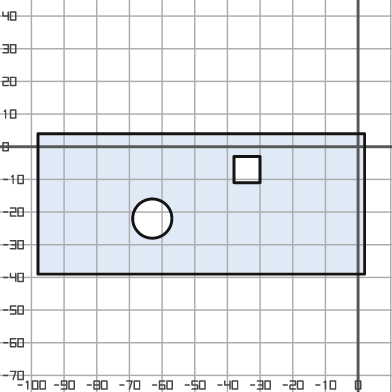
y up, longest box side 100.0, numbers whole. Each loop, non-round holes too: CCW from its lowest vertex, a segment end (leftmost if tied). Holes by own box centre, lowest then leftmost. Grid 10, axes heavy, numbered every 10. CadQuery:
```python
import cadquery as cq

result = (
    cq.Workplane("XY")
    .moveTo(-98.0, -39.0)
    .lineTo(2.0, -39.0)
    .lineTo(2.0, 4.0)
    .lineTo(-98.0, 4.0)
    .close()
    .moveTo(-63.0, -22.0)
    .circle(6.0)
    .moveTo(-38.0, -11.0)
    .lineTo(-30.0, -11.0)
    .lineTo(-30.0, -3.0)
    .lineTo(-38.0, -3.0)
    .close()
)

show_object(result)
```